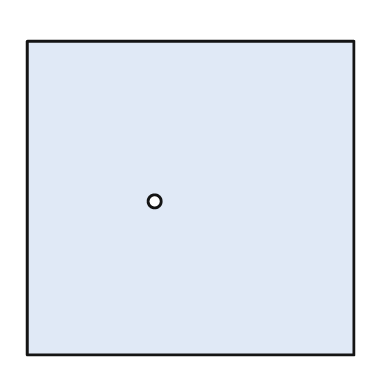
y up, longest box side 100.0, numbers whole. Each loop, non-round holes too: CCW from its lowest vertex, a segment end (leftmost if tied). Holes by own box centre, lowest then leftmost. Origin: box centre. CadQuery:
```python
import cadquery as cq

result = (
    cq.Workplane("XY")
    .moveTo(-50.0, -48.0)
    .lineTo(50.0, -48.0)
    .lineTo(50.0, 48.0)
    .lineTo(-50.0, 48.0)
    .close()
    .moveTo(-11.0, -1.0)
    .circle(2.0)
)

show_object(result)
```